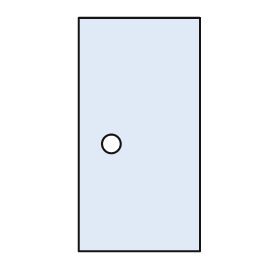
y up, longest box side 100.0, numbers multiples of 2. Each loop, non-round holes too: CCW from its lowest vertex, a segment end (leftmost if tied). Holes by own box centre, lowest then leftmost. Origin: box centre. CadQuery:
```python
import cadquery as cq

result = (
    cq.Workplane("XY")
    .moveTo(-26.0, -50.0)
    .lineTo(26.0, -50.0)
    .lineTo(26.0, 50.0)
    .lineTo(-26.0, 50.0)
    .close()
    .moveTo(-12.0, -4.0)
    .circle(4.0)
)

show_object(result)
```